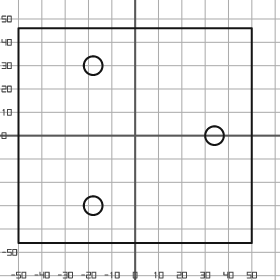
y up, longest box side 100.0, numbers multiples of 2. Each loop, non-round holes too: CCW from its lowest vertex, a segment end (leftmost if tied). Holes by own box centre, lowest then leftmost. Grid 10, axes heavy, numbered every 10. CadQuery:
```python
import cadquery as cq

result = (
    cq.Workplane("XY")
    .moveTo(-50.0, -46.0)
    .lineTo(50.0, -46.0)
    .lineTo(50.0, 46.0)
    .lineTo(-50.0, 46.0)
    .close()
    .moveTo(-18.0, -30.0)
    .circle(4.0)
    .moveTo(34.0, 0.0)
    .circle(4.0)
    .moveTo(-18.0, 30.0)
    .circle(4.0)
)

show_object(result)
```